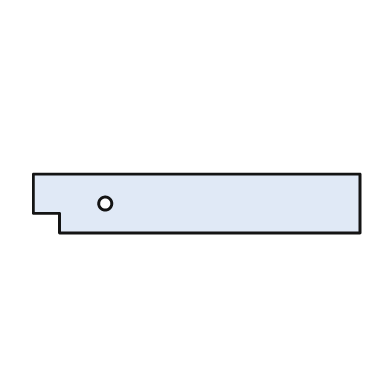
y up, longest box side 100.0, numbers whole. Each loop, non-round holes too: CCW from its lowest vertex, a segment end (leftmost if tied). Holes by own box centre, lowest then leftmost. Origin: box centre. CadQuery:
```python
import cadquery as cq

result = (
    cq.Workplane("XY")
    .moveTo(-42.0, -9.0)
    .lineTo(50.0, -9.0)
    .lineTo(50.0, 9.0)
    .lineTo(-50.0, 9.0)
    .lineTo(-50.0, -3.0)
    .lineTo(-42.0, -3.0)
    .close()
    .moveTo(-28.0, 0.0)
    .circle(2.0)
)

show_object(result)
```